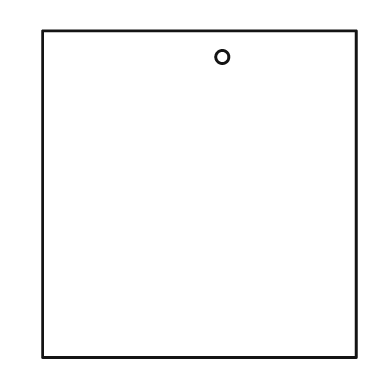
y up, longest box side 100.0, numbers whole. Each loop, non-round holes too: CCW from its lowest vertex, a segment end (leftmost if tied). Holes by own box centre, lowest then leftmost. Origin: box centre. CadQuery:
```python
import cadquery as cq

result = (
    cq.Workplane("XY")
    .moveTo(-48.0, -50.0)
    .lineTo(48.0, -50.0)
    .lineTo(48.0, 50.0)
    .lineTo(-48.0, 50.0)
    .close()
    .moveTo(7.0, 42.0)
    .circle(2.0)
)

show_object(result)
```